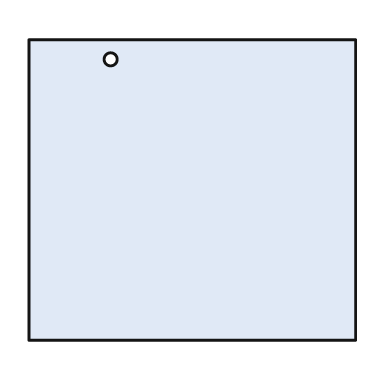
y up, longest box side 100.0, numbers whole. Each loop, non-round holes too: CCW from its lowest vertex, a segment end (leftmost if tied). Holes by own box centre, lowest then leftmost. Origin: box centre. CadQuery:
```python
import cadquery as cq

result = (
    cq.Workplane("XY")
    .moveTo(-50.0, -46.0)
    .lineTo(50.0, -46.0)
    .lineTo(50.0, 46.0)
    .lineTo(-50.0, 46.0)
    .close()
    .moveTo(-25.0, 40.0)
    .circle(2.0)
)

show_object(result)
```